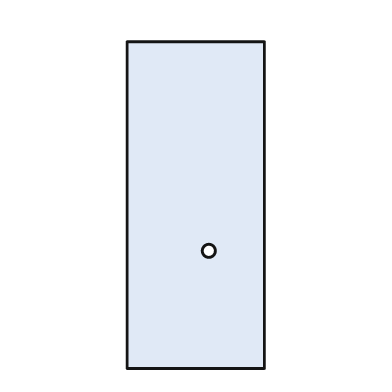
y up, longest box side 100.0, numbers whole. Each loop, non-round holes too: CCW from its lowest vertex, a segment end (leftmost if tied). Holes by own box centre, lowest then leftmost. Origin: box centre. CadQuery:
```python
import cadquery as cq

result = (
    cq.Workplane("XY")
    .moveTo(-21.0, -50.0)
    .lineTo(21.0, -50.0)
    .lineTo(21.0, 50.0)
    .lineTo(-21.0, 50.0)
    .close()
    .moveTo(4.0, -14.0)
    .circle(2.0)
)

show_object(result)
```